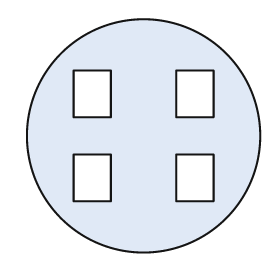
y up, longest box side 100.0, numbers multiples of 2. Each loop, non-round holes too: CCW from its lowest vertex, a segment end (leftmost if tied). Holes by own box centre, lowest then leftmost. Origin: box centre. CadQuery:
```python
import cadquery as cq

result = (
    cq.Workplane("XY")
    .moveTo(0.0, 0.0)
    .circle(50.0)
    .moveTo(-30.0, -28.0)
    .lineTo(-14.0, -28.0)
    .lineTo(-14.0, -8.0)
    .lineTo(-30.0, -8.0)
    .close()
    .moveTo(14.0, -28.0)
    .lineTo(30.0, -28.0)
    .lineTo(30.0, -8.0)
    .lineTo(14.0, -8.0)
    .close()
    .moveTo(-30.0, 8.0)
    .lineTo(-14.0, 8.0)
    .lineTo(-14.0, 28.0)
    .lineTo(-30.0, 28.0)
    .close()
    .moveTo(14.0, 8.0)
    .lineTo(30.0, 8.0)
    .lineTo(30.0, 28.0)
    .lineTo(14.0, 28.0)
    .close()
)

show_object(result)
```